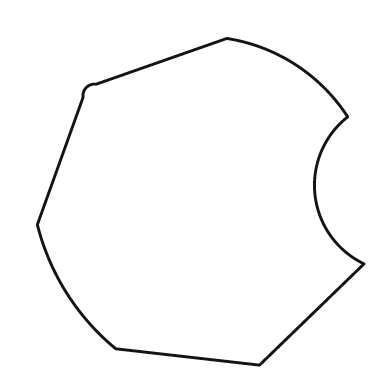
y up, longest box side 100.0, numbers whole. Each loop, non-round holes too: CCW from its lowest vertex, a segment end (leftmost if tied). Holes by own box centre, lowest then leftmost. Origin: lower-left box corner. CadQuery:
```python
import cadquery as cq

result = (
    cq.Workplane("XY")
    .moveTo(68.0, 0.0)
    .lineTo(100.0, 31.0)
    .threePointArc((85.0, 52.0), (95.0, 76.0))
    .threePointArc((79.0, 92.0), (58.0, 100.0))
    .lineTo(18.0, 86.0)
    .threePointArc((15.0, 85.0), (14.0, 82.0))
    .lineTo(0.0, 43.0)
    .threePointArc((9.0, 22.0), (24.0, 5.0))
    .close()
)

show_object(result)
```